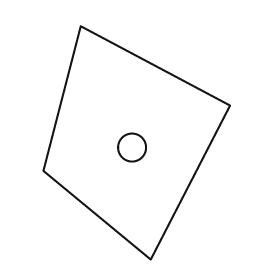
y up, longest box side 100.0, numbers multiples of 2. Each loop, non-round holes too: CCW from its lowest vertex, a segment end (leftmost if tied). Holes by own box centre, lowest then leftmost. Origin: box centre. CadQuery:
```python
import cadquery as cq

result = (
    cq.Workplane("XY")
    .moveTo(6.0, -50.0)
    .lineTo(40.0, 16.0)
    .lineTo(-24.0, 50.0)
    .lineTo(-40.0, -12.0)
    .close()
    .moveTo(-2.0, -2.0)
    .circle(6.0)
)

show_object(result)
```